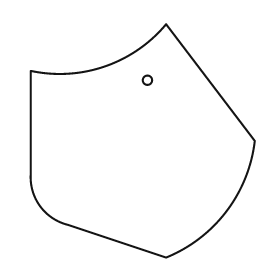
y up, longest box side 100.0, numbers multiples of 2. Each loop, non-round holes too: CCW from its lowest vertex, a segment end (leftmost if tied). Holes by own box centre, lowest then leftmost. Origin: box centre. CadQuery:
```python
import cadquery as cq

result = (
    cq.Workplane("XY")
    .moveTo(10.0, -50.0)
    .threePointArc((36.0, -30.0), (48.0, 0.0))
    .lineTo(10.0, 50.0)
    .threePointArc((-16.0, 32.0), (-48.0, 30.0))
    .lineTo(-48.0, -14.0)
    .threePointArc((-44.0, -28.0), (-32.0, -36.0))
    .close()
    .moveTo(2.0, 26.0)
    .circle(2.0)
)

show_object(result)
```